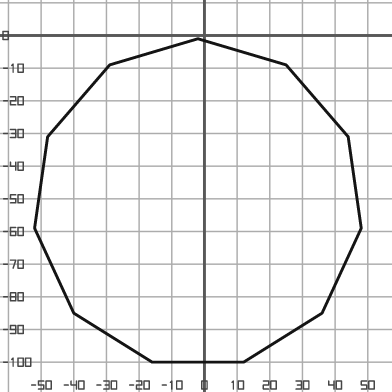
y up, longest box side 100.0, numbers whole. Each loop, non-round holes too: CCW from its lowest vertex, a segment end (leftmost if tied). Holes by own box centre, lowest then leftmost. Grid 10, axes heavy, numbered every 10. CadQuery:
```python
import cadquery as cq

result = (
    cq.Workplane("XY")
    .moveTo(-16.0, -100.0)
    .lineTo(12.0, -100.0)
    .lineTo(36.0, -85.0)
    .lineTo(48.0, -59.0)
    .lineTo(44.0, -31.0)
    .lineTo(25.0, -9.0)
    .lineTo(-2.0, -1.0)
    .lineTo(-29.0, -9.0)
    .lineTo(-48.0, -31.0)
    .lineTo(-52.0, -59.0)
    .lineTo(-40.0, -85.0)
    .close()
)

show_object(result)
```